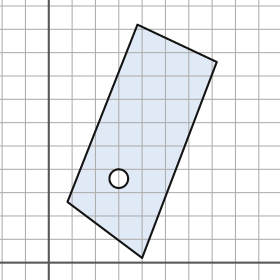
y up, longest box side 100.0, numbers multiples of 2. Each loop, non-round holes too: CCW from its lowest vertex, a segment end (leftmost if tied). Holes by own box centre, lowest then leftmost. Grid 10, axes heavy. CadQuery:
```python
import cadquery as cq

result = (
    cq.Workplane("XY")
    .moveTo(40.0, 2.0)
    .lineTo(72.0, 86.0)
    .lineTo(38.0, 102.0)
    .lineTo(8.0, 26.0)
    .close()
    .moveTo(30.0, 36.0)
    .circle(4.0)
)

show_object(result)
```